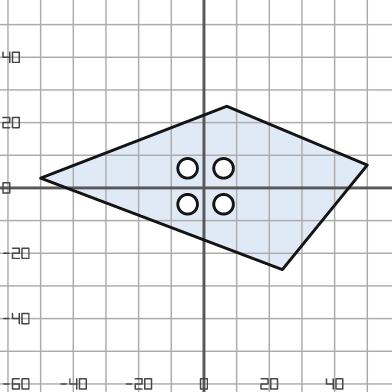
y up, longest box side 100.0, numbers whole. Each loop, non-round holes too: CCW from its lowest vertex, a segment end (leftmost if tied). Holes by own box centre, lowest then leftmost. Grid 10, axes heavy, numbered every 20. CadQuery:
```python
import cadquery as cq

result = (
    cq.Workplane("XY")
    .moveTo(24.0, -25.0)
    .lineTo(50.0, 7.0)
    .lineTo(7.0, 25.0)
    .lineTo(-50.0, 3.0)
    .close()
    .moveTo(-5.0, -5.0)
    .circle(3.0)
    .moveTo(6.0, -5.0)
    .circle(3.0)
    .moveTo(-5.0, 6.0)
    .circle(3.0)
    .moveTo(6.0, 6.0)
    .circle(3.0)
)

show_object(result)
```